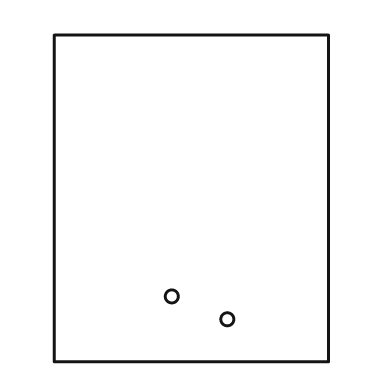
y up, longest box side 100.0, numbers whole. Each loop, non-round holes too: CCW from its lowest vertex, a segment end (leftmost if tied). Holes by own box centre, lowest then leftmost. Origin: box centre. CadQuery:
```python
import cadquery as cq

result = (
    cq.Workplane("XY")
    .moveTo(-42.0, -50.0)
    .lineTo(42.0, -50.0)
    .lineTo(42.0, 50.0)
    .lineTo(-42.0, 50.0)
    .close()
    .moveTo(11.0, -37.0)
    .circle(2.0)
    .moveTo(-6.0, -30.0)
    .circle(2.0)
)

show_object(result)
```